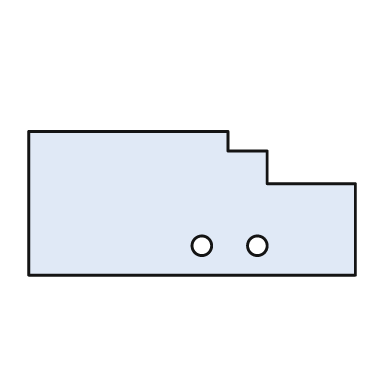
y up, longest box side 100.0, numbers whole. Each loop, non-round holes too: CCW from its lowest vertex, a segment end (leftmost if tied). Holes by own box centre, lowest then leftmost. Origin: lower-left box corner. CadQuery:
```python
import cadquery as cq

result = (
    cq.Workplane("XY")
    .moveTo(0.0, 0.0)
    .lineTo(100.0, 0.0)
    .lineTo(100.0, 28.0)
    .lineTo(73.0, 28.0)
    .lineTo(73.0, 38.0)
    .lineTo(61.0, 38.0)
    .lineTo(61.0, 44.0)
    .lineTo(0.0, 44.0)
    .close()
    .moveTo(53.0, 9.0)
    .circle(3.0)
    .moveTo(70.0, 9.0)
    .circle(3.0)
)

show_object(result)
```